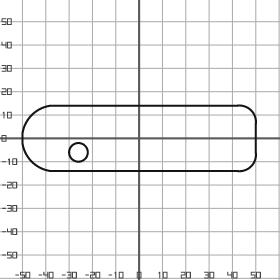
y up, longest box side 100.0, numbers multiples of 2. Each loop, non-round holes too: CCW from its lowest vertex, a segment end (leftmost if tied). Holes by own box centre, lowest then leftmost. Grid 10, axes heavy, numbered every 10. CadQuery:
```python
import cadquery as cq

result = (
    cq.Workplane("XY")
    .moveTo(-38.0, -14.0)
    .lineTo(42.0, -14.0)
    .threePointArc((48.0, -12.0), (50.0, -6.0))
    .lineTo(50.0, 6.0)
    .threePointArc((48.0, 12.0), (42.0, 14.0))
    .lineTo(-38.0, 14.0)
    .threePointArc((-46.0, 10.0), (-50.0, 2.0))
    .lineTo(-50.0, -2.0)
    .threePointArc((-46.0, -10.0), (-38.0, -14.0))
    .close()
    .moveTo(-26.0, -6.0)
    .circle(4.0)
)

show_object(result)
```